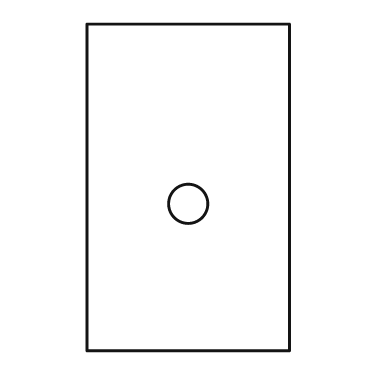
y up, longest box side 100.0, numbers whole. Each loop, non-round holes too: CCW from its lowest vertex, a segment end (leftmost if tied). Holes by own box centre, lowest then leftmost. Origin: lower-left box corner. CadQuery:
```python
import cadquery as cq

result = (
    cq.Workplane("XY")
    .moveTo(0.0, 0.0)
    .lineTo(62.0, 0.0)
    .lineTo(62.0, 100.0)
    .lineTo(0.0, 100.0)
    .close()
    .moveTo(31.0, 45.0)
    .circle(6.0)
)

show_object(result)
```